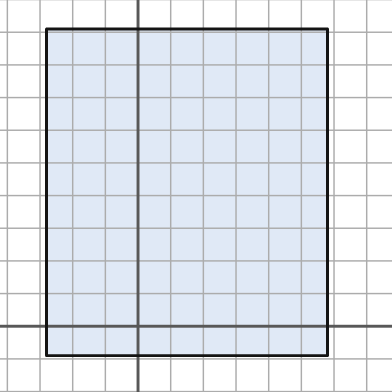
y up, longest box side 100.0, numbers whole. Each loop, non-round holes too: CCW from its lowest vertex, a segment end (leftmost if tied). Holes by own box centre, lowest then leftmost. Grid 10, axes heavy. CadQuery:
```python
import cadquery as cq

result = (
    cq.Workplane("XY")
    .moveTo(-28.0, -9.0)
    .lineTo(58.0, -9.0)
    .lineTo(58.0, 91.0)
    .lineTo(-28.0, 91.0)
    .close()
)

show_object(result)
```